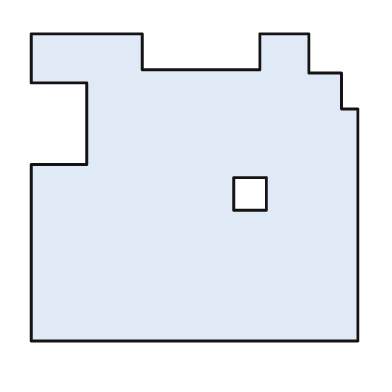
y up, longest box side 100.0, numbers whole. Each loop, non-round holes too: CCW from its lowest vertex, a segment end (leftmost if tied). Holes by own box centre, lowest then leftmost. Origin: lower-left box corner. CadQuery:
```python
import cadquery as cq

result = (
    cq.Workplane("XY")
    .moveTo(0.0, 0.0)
    .lineTo(100.0, 0.0)
    .lineTo(100.0, 71.0)
    .lineTo(95.0, 71.0)
    .lineTo(95.0, 82.0)
    .lineTo(85.0, 82.0)
    .lineTo(85.0, 94.0)
    .lineTo(70.0, 94.0)
    .lineTo(70.0, 83.0)
    .lineTo(34.0, 83.0)
    .lineTo(34.0, 94.0)
    .lineTo(0.0, 94.0)
    .lineTo(0.0, 79.0)
    .lineTo(17.0, 79.0)
    .lineTo(17.0, 54.0)
    .lineTo(0.0, 54.0)
    .close()
    .moveTo(62.0, 40.0)
    .lineTo(72.0, 40.0)
    .lineTo(72.0, 50.0)
    .lineTo(62.0, 50.0)
    .close()
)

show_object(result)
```